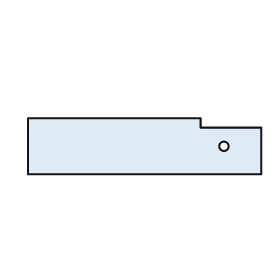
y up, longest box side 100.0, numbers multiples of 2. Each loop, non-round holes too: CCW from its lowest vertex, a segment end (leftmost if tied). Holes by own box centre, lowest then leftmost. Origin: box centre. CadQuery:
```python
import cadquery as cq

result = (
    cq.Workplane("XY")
    .moveTo(-50.0, -12.0)
    .lineTo(50.0, -12.0)
    .lineTo(50.0, 8.0)
    .lineTo(24.0, 8.0)
    .lineTo(24.0, 12.0)
    .lineTo(-50.0, 12.0)
    .close()
    .moveTo(34.0, 0.0)
    .circle(2.0)
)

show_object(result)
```